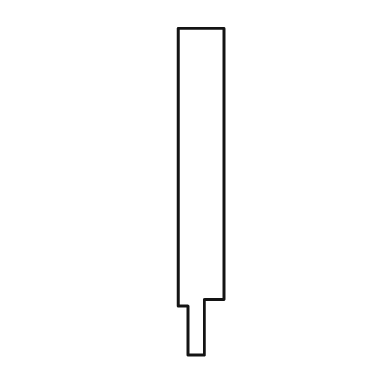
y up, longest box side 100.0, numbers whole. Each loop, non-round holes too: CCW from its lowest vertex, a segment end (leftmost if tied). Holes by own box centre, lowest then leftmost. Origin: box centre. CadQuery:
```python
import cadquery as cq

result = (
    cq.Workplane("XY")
    .moveTo(-4.0, -50.0)
    .lineTo(1.0, -50.0)
    .lineTo(1.0, -33.0)
    .lineTo(7.0, -33.0)
    .lineTo(7.0, 50.0)
    .lineTo(-7.0, 50.0)
    .lineTo(-7.0, -35.0)
    .lineTo(-4.0, -35.0)
    .close()
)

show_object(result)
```